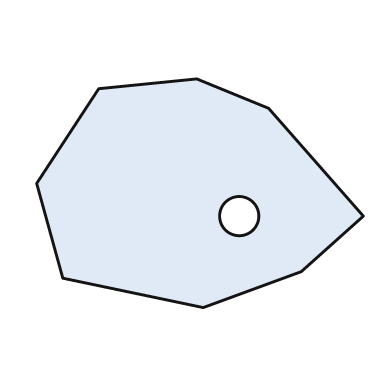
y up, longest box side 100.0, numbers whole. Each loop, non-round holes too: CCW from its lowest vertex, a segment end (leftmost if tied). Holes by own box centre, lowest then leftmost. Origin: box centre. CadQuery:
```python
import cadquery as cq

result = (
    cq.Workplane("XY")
    .moveTo(1.0, -35.0)
    .lineTo(31.0, -24.0)
    .lineTo(50.0, -7.0)
    .lineTo(21.0, 26.0)
    .lineTo(-1.0, 35.0)
    .lineTo(-31.0, 32.0)
    .lineTo(-50.0, 3.0)
    .lineTo(-42.0, -26.0)
    .close()
    .moveTo(12.0, -7.0)
    .circle(6.0)
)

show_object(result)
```